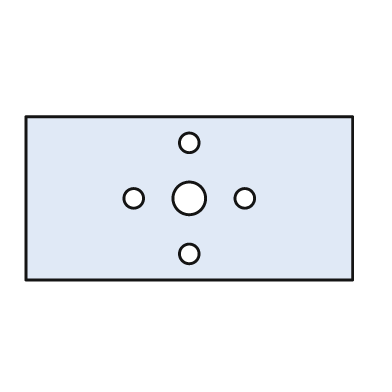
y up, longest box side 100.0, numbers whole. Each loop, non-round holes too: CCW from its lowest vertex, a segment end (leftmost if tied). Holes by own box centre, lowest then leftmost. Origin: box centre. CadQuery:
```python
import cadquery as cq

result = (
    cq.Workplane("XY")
    .moveTo(-50.0, -25.0)
    .lineTo(50.0, -25.0)
    .lineTo(50.0, 25.0)
    .lineTo(-50.0, 25.0)
    .close()
    .moveTo(0.0, -17.0)
    .circle(3.0)
    .moveTo(-17.0, 0.0)
    .circle(3.0)
    .moveTo(0.0, 0.0)
    .circle(5.0)
    .moveTo(17.0, 0.0)
    .circle(3.0)
    .moveTo(0.0, 17.0)
    .circle(3.0)
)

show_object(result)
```